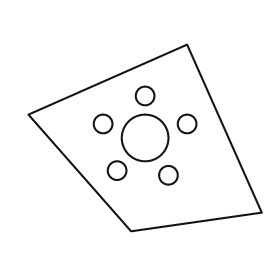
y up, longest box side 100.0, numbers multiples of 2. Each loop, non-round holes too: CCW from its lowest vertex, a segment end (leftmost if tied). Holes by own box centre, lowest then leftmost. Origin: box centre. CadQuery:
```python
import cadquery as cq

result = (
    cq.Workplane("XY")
    .moveTo(-6.0, -40.0)
    .lineTo(50.0, -32.0)
    .lineTo(18.0, 40.0)
    .lineTo(-50.0, 10.0)
    .close()
    .moveTo(10.0, -16.0)
    .circle(4.0)
    .moveTo(-12.0, -14.0)
    .circle(4.0)
    .moveTo(0.0, 0.0)
    .circle(10.0)
    .moveTo(-18.0, 6.0)
    .circle(4.0)
    .moveTo(18.0, 6.0)
    .circle(4.0)
    .moveTo(0.0, 18.0)
    .circle(4.0)
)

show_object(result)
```